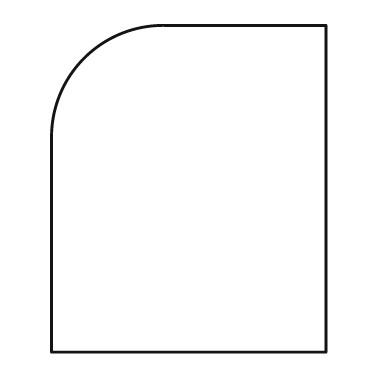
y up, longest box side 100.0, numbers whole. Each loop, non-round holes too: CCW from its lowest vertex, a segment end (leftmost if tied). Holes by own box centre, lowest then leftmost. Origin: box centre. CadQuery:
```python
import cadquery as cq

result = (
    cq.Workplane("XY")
    .moveTo(-42.0, -50.0)
    .lineTo(42.0, -50.0)
    .lineTo(42.0, 50.0)
    .lineTo(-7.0, 50.0)
    .threePointArc((-32.0, 40.0), (-42.0, 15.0))
    .close()
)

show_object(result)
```